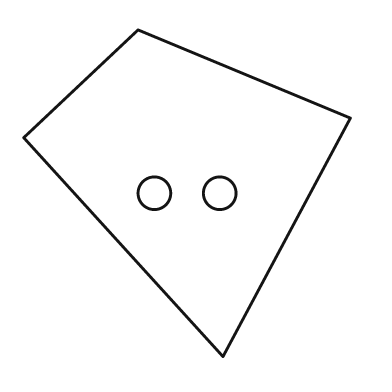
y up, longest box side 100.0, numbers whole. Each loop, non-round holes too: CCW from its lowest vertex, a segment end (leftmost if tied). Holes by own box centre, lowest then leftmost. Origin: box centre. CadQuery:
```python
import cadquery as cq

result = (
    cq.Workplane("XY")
    .moveTo(11.0, -50.0)
    .lineTo(50.0, 23.0)
    .lineTo(-15.0, 50.0)
    .lineTo(-50.0, 17.0)
    .close()
    .moveTo(-10.0, 0.0)
    .circle(5.0)
    .moveTo(10.0, 0.0)
    .circle(5.0)
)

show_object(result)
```